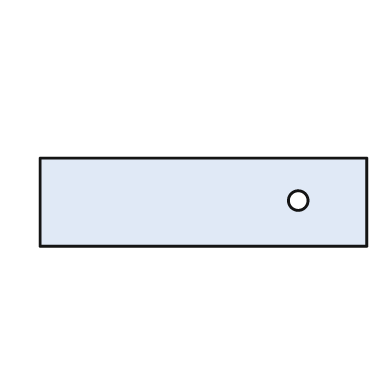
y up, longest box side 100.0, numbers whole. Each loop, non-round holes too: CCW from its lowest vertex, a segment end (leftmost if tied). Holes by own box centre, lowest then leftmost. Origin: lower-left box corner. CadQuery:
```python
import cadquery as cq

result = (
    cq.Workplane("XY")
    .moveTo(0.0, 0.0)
    .lineTo(100.0, 0.0)
    .lineTo(100.0, 27.0)
    .lineTo(0.0, 27.0)
    .close()
    .moveTo(79.0, 14.0)
    .circle(3.0)
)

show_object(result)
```